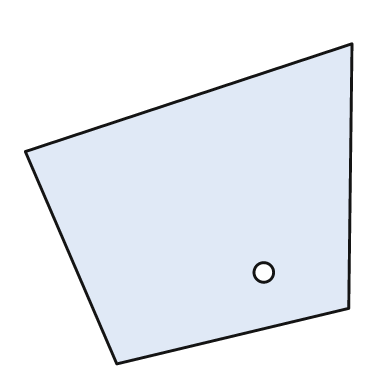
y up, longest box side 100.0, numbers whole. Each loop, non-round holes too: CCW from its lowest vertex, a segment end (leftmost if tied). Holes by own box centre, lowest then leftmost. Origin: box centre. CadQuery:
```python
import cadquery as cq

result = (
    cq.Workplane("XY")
    .moveTo(-22.0, -49.0)
    .lineTo(49.0, -32.0)
    .lineTo(50.0, 49.0)
    .lineTo(-50.0, 16.0)
    .close()
    .moveTo(23.0, -21.0)
    .circle(3.0)
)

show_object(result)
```